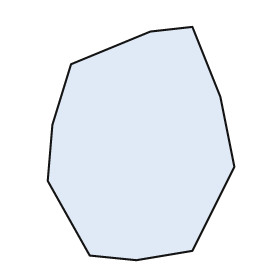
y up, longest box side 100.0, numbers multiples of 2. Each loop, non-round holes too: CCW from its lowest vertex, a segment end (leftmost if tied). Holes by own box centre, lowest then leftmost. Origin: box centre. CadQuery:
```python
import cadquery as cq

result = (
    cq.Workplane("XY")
    .moveTo(-2.0, -50.0)
    .lineTo(22.0, -46.0)
    .lineTo(40.0, -10.0)
    .lineTo(34.0, 20.0)
    .lineTo(22.0, 50.0)
    .lineTo(4.0, 48.0)
    .lineTo(-30.0, 34.0)
    .lineTo(-38.0, 8.0)
    .lineTo(-40.0, -16.0)
    .lineTo(-22.0, -48.0)
    .close()
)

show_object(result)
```